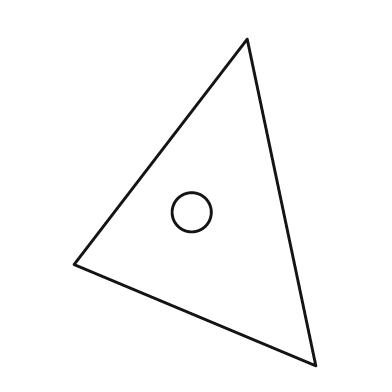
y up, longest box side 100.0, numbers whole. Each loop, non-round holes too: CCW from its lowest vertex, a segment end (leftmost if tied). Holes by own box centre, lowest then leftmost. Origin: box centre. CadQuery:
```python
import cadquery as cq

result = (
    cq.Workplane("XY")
    .moveTo(37.0, -50.0)
    .lineTo(16.0, 50.0)
    .lineTo(-37.0, -19.0)
    .close()
    .moveTo(-1.0, -3.0)
    .circle(6.0)
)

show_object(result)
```